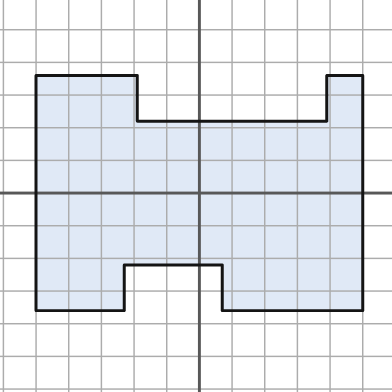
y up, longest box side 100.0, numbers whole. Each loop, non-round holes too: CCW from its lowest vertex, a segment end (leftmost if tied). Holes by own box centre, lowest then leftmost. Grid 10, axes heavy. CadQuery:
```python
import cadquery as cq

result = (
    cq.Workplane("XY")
    .moveTo(-50.0, -36.0)
    .lineTo(-23.0, -36.0)
    .lineTo(-23.0, -22.0)
    .lineTo(7.0, -22.0)
    .lineTo(7.0, -36.0)
    .lineTo(50.0, -36.0)
    .lineTo(50.0, 36.0)
    .lineTo(39.0, 36.0)
    .lineTo(39.0, 22.0)
    .lineTo(-19.0, 22.0)
    .lineTo(-19.0, 36.0)
    .lineTo(-50.0, 36.0)
    .close()
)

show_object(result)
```